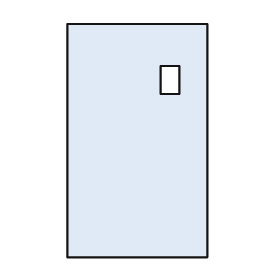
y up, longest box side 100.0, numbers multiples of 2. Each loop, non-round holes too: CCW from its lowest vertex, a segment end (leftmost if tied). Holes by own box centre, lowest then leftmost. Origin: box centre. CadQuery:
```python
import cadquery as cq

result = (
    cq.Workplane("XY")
    .moveTo(-30.0, -50.0)
    .lineTo(30.0, -50.0)
    .lineTo(30.0, 50.0)
    .lineTo(-30.0, 50.0)
    .close()
    .moveTo(10.0, 20.0)
    .lineTo(18.0, 20.0)
    .lineTo(18.0, 32.0)
    .lineTo(10.0, 32.0)
    .close()
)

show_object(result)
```